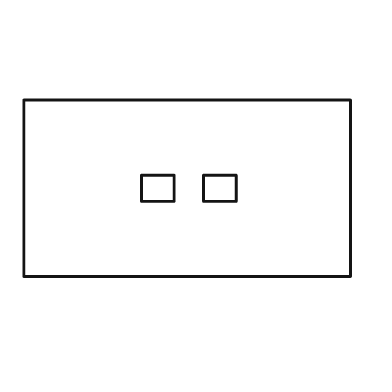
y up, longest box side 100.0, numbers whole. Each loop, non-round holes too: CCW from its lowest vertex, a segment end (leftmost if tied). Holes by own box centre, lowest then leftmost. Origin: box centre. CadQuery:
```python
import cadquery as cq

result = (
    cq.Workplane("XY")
    .moveTo(-50.0, -27.0)
    .lineTo(50.0, -27.0)
    .lineTo(50.0, 27.0)
    .lineTo(-50.0, 27.0)
    .close()
    .moveTo(-14.0, -4.0)
    .lineTo(-4.0, -4.0)
    .lineTo(-4.0, 4.0)
    .lineTo(-14.0, 4.0)
    .close()
    .moveTo(5.0, -4.0)
    .lineTo(15.0, -4.0)
    .lineTo(15.0, 4.0)
    .lineTo(5.0, 4.0)
    .close()
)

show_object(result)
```